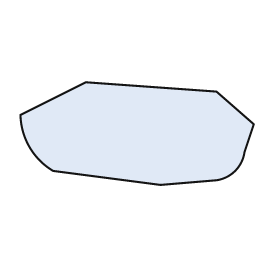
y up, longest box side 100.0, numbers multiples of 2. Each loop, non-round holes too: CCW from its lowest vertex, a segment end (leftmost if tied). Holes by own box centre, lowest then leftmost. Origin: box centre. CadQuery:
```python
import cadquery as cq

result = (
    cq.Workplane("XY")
    .moveTo(10.0, -22.0)
    .lineTo(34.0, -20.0)
    .threePointArc((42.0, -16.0), (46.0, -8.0))
    .lineTo(50.0, 4.0)
    .lineTo(34.0, 18.0)
    .lineTo(-22.0, 22.0)
    .lineTo(-50.0, 8.0)
    .threePointArc((-46.0, -6.0), (-36.0, -16.0))
    .close()
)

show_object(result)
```